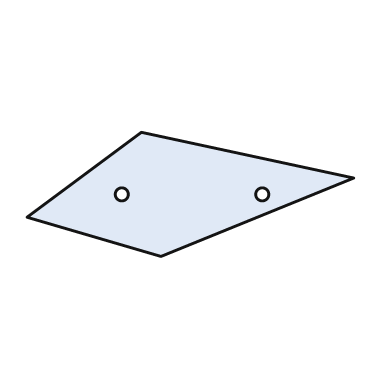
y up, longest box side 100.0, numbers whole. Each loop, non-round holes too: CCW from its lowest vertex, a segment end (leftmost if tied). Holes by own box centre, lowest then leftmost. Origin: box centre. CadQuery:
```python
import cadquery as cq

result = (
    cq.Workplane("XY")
    .moveTo(-9.0, -19.0)
    .lineTo(50.0, 5.0)
    .lineTo(-15.0, 19.0)
    .lineTo(-50.0, -7.0)
    .close()
    .moveTo(-21.0, 0.0)
    .circle(2.0)
    .moveTo(22.0, 0.0)
    .circle(2.0)
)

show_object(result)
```